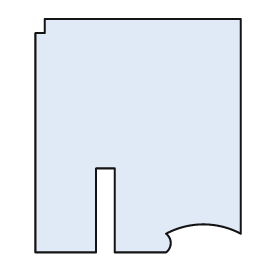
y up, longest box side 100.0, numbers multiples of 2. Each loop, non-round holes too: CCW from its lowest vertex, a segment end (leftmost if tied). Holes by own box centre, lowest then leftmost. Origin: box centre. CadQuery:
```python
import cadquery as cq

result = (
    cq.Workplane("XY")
    .moveTo(-44.0, -50.0)
    .lineTo(-18.0, -50.0)
    .lineTo(-18.0, -14.0)
    .lineTo(-10.0, -14.0)
    .lineTo(-10.0, -50.0)
    .lineTo(12.0, -50.0)
    .threePointArc((14.0, -46.0), (12.0, -42.0))
    .threePointArc((28.0, -38.0), (44.0, -42.0))
    .lineTo(44.0, 50.0)
    .lineTo(-40.0, 50.0)
    .lineTo(-40.0, 44.0)
    .lineTo(-44.0, 44.0)
    .close()
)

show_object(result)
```